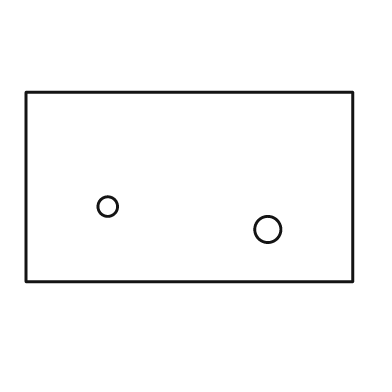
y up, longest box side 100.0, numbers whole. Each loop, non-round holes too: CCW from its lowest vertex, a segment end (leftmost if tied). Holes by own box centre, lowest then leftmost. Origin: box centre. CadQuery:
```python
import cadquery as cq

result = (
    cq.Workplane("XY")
    .moveTo(-50.0, -29.0)
    .lineTo(50.0, -29.0)
    .lineTo(50.0, 29.0)
    .lineTo(-50.0, 29.0)
    .close()
    .moveTo(24.0, -13.0)
    .circle(4.0)
    .moveTo(-25.0, -6.0)
    .circle(3.0)
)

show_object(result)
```